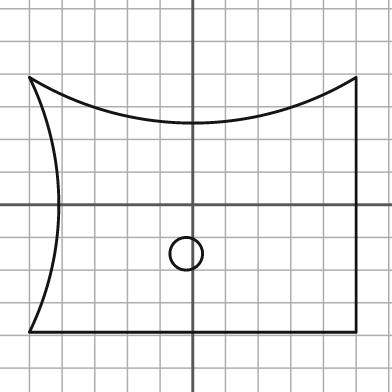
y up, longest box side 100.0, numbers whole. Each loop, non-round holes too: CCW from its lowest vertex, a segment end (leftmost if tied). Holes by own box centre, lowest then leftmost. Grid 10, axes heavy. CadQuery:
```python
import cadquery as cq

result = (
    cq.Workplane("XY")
    .moveTo(-50.0, -39.0)
    .lineTo(50.0, -39.0)
    .lineTo(50.0, 39.0)
    .threePointArc((0.0, 25.0), (-50.0, 39.0))
    .threePointArc((-41.0, 0.0), (-50.0, -39.0))
    .close()
    .moveTo(-2.0, -15.0)
    .circle(5.0)
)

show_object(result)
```